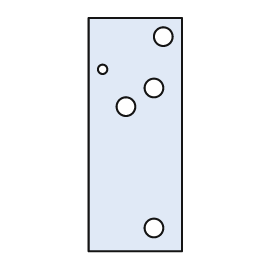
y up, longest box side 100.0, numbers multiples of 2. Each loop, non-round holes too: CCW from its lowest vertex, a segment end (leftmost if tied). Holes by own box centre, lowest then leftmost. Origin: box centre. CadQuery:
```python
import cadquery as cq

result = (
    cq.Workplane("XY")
    .moveTo(-20.0, -50.0)
    .lineTo(20.0, -50.0)
    .lineTo(20.0, 50.0)
    .lineTo(-20.0, 50.0)
    .close()
    .moveTo(8.0, -40.0)
    .circle(4.0)
    .moveTo(-4.0, 12.0)
    .circle(4.0)
    .moveTo(8.0, 20.0)
    .circle(4.0)
    .moveTo(-14.0, 28.0)
    .circle(2.0)
    .moveTo(12.0, 42.0)
    .circle(4.0)
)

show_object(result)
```